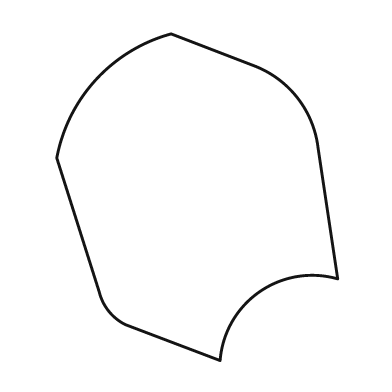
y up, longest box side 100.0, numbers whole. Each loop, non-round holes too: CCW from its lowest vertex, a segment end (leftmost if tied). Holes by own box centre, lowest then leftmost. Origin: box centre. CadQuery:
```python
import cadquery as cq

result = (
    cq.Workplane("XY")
    .moveTo(7.0, -50.0)
    .threePointArc((19.0, -29.0), (43.0, -25.0))
    .lineTo(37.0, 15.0)
    .threePointArc((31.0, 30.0), (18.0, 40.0))
    .lineTo(-8.0, 50.0)
    .threePointArc((-31.0, 36.0), (-43.0, 12.0))
    .lineTo(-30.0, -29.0)
    .threePointArc((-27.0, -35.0), (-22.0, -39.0))
    .close()
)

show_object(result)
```